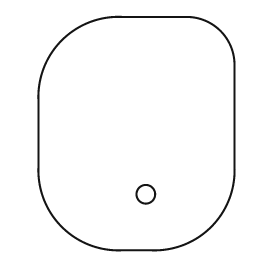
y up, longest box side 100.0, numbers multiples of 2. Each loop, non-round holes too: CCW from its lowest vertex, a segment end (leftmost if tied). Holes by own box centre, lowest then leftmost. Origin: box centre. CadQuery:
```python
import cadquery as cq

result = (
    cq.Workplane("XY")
    .moveTo(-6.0, -50.0)
    .lineTo(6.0, -50.0)
    .threePointArc((32.0, -40.0), (42.0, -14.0))
    .lineTo(42.0, 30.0)
    .threePointArc((36.0, 44.0), (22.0, 50.0))
    .lineTo(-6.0, 50.0)
    .threePointArc((-32.0, 40.0), (-42.0, 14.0))
    .lineTo(-42.0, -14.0)
    .threePointArc((-32.0, -40.0), (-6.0, -50.0))
    .close()
    .moveTo(4.0, -26.0)
    .circle(4.0)
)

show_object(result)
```